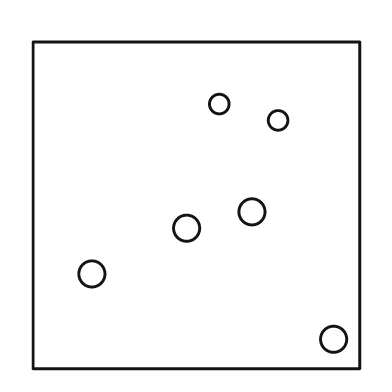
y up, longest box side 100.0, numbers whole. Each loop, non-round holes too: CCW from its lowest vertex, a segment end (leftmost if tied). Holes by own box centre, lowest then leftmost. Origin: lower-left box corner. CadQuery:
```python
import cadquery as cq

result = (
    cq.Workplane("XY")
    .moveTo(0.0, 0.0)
    .lineTo(100.0, 0.0)
    .lineTo(100.0, 100.0)
    .lineTo(0.0, 100.0)
    .close()
    .moveTo(92.0, 9.0)
    .circle(4.0)
    .moveTo(18.0, 29.0)
    .circle(4.0)
    .moveTo(47.0, 43.0)
    .circle(4.0)
    .moveTo(67.0, 48.0)
    .circle(4.0)
    .moveTo(75.0, 76.0)
    .circle(3.0)
    .moveTo(57.0, 81.0)
    .circle(3.0)
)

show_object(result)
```